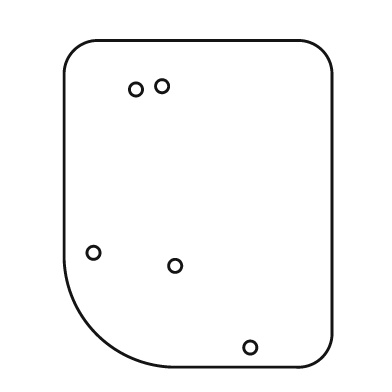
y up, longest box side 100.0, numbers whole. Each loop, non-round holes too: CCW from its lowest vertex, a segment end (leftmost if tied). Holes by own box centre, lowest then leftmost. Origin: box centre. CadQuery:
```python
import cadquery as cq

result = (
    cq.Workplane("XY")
    .moveTo(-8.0, -50.0)
    .lineTo(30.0, -50.0)
    .threePointArc((38.0, -47.0), (41.0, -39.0))
    .lineTo(41.0, 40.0)
    .threePointArc((38.0, 47.0), (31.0, 50.0))
    .lineTo(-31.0, 50.0)
    .threePointArc((-38.0, 47.0), (-41.0, 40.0))
    .lineTo(-41.0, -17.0)
    .threePointArc((-31.0, -40.0), (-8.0, -50.0))
    .close()
    .moveTo(16.0, -44.0)
    .circle(2.0)
    .moveTo(-7.0, -19.0)
    .circle(2.0)
    .moveTo(-32.0, -15.0)
    .circle(2.0)
    .moveTo(-19.0, 35.0)
    .circle(2.0)
    .moveTo(-11.0, 36.0)
    .circle(2.0)
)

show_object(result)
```